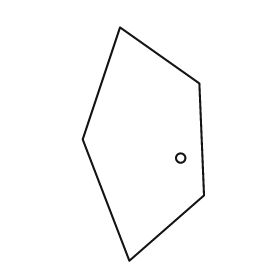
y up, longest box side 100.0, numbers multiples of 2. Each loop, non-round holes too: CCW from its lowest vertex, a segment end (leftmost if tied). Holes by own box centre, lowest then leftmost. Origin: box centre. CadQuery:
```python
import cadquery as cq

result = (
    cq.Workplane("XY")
    .moveTo(-6.0, -50.0)
    .lineTo(26.0, -22.0)
    .lineTo(24.0, 26.0)
    .lineTo(-10.0, 50.0)
    .lineTo(-26.0, 2.0)
    .close()
    .moveTo(16.0, -6.0)
    .circle(2.0)
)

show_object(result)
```